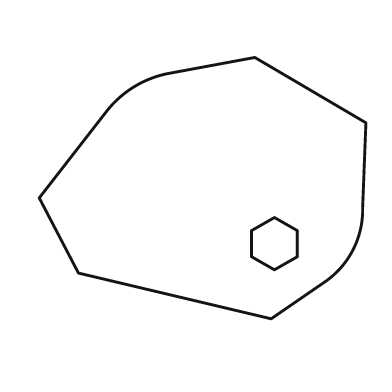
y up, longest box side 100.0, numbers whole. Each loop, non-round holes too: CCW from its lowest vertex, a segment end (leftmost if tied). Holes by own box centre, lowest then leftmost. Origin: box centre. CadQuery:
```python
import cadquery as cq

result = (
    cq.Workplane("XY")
    .moveTo(21.0, -40.0)
    .lineTo(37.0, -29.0)
    .threePointArc((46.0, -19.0), (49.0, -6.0))
    .lineTo(50.0, 20.0)
    .lineTo(16.0, 40.0)
    .lineTo(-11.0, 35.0)
    .threePointArc((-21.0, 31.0), (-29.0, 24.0))
    .lineTo(-50.0, -3.0)
    .lineTo(-38.0, -26.0)
    .close()
    .moveTo(22.0, -25.0)
    .lineTo(29.0, -21.0)
    .lineTo(29.0, -13.0)
    .lineTo(22.0, -9.0)
    .lineTo(15.0, -13.0)
    .lineTo(15.0, -21.0)
    .close()
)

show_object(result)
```